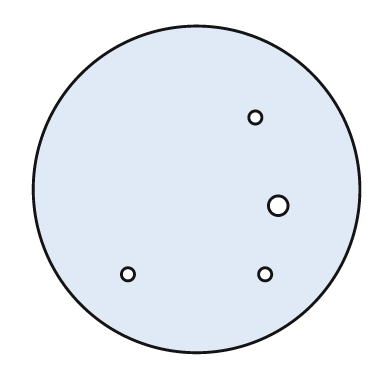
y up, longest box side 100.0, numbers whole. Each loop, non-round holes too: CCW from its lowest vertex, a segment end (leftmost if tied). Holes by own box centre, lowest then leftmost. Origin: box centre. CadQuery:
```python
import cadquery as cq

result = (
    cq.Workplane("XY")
    .moveTo(0.0, 0.0)
    .circle(50.0)
    .moveTo(-21.0, -26.0)
    .circle(2.0)
    .moveTo(21.0, -26.0)
    .circle(2.0)
    .moveTo(25.0, -5.0)
    .circle(3.0)
    .moveTo(18.0, 22.0)
    .circle(2.0)
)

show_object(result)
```